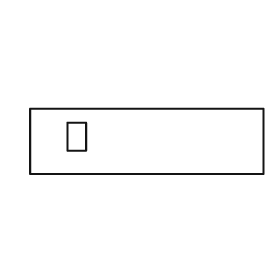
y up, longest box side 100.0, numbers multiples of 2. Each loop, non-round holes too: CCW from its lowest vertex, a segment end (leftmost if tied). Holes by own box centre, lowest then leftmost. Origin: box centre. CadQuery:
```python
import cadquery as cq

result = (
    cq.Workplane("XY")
    .moveTo(-50.0, -14.0)
    .lineTo(50.0, -14.0)
    .lineTo(50.0, 14.0)
    .lineTo(-50.0, 14.0)
    .close()
    .moveTo(-34.0, -4.0)
    .lineTo(-26.0, -4.0)
    .lineTo(-26.0, 8.0)
    .lineTo(-34.0, 8.0)
    .close()
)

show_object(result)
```